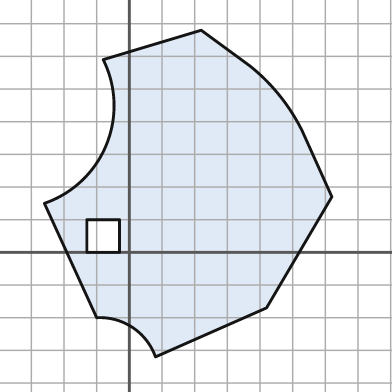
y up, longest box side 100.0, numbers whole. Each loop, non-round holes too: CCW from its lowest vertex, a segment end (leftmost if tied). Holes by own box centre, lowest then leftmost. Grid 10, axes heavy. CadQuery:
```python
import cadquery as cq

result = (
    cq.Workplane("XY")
    .moveTo(8.0, -32.0)
    .lineTo(42.0, -17.0)
    .lineTo(62.0, 17.0)
    .lineTo(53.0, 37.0)
    .threePointArc((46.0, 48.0), (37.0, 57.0))
    .lineTo(22.0, 68.0)
    .lineTo(-8.0, 59.0)
    .threePointArc((-7.0, 33.0), (-26.0, 15.0))
    .lineTo(-10.0, -20.0)
    .threePointArc((1.0, -23.0), (8.0, -32.0))
    .close()
    .moveTo(-13.0, 0.0)
    .lineTo(-3.0, 0.0)
    .lineTo(-3.0, 10.0)
    .lineTo(-13.0, 10.0)
    .close()
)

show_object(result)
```